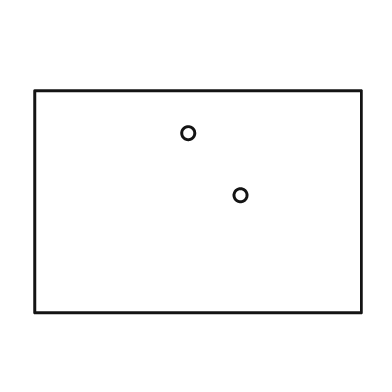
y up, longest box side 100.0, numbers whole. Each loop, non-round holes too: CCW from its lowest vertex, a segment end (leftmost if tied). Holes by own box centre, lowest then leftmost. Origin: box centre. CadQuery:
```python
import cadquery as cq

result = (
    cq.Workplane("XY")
    .moveTo(-50.0, -34.0)
    .lineTo(50.0, -34.0)
    .lineTo(50.0, 34.0)
    .lineTo(-50.0, 34.0)
    .close()
    .moveTo(13.0, 2.0)
    .circle(2.0)
    .moveTo(-3.0, 21.0)
    .circle(2.0)
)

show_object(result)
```